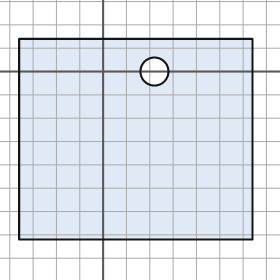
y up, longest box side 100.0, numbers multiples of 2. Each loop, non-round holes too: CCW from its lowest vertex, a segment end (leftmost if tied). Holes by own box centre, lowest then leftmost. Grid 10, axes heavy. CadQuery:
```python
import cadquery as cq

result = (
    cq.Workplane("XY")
    .moveTo(-36.0, -72.0)
    .lineTo(64.0, -72.0)
    .lineTo(64.0, 14.0)
    .lineTo(-36.0, 14.0)
    .close()
    .moveTo(22.0, 0.0)
    .circle(6.0)
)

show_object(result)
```